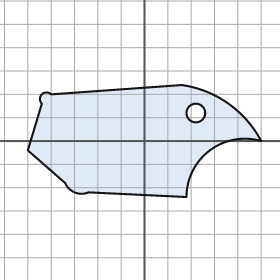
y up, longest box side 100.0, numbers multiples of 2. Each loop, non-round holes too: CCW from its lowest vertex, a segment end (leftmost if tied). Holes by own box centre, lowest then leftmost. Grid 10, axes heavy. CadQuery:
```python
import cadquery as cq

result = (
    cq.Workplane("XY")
    .moveTo(18.0, -24.0)
    .threePointArc((28.0, -4.0), (50.0, 0.0))
    .threePointArc((36.0, 16.0), (16.0, 24.0))
    .lineTo(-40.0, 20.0)
    .threePointArc((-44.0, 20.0), (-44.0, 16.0))
    .lineTo(-50.0, -4.0)
    .lineTo(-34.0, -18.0)
    .threePointArc((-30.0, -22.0), (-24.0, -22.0))
    .close()
    .moveTo(22.0, 12.0)
    .circle(4.0)
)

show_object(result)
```